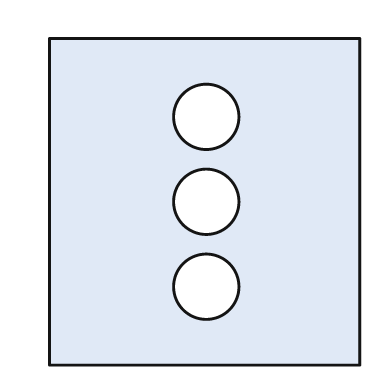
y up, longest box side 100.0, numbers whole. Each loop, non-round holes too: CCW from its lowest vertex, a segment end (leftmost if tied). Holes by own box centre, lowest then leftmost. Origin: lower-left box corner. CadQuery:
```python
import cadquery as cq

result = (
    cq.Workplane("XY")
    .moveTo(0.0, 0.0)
    .lineTo(95.0, 0.0)
    .lineTo(95.0, 100.0)
    .lineTo(0.0, 100.0)
    .close()
    .moveTo(48.0, 24.0)
    .circle(10.0)
    .moveTo(48.0, 50.0)
    .circle(10.0)
    .moveTo(48.0, 76.0)
    .circle(10.0)
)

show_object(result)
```